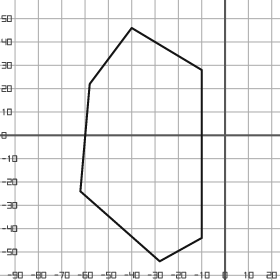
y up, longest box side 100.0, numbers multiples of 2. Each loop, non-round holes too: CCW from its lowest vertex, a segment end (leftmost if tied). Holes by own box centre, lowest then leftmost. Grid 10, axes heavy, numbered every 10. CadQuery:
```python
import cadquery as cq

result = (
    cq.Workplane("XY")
    .moveTo(-28.0, -54.0)
    .lineTo(-10.0, -44.0)
    .lineTo(-10.0, 28.0)
    .lineTo(-40.0, 46.0)
    .lineTo(-58.0, 22.0)
    .lineTo(-62.0, -24.0)
    .close()
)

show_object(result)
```